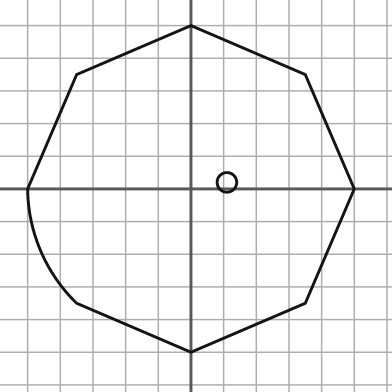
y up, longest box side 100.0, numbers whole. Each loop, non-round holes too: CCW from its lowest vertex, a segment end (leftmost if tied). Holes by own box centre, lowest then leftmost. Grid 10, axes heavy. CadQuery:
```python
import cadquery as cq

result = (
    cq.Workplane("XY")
    .moveTo(0.0, -50.0)
    .lineTo(35.0, -35.0)
    .lineTo(50.0, 0.0)
    .lineTo(35.0, 35.0)
    .lineTo(0.0, 50.0)
    .lineTo(-35.0, 35.0)
    .lineTo(-50.0, 0.0)
    .threePointArc((-46.0, -19.0), (-35.0, -35.0))
    .close()
    .moveTo(11.0, 2.0)
    .circle(3.0)
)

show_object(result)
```